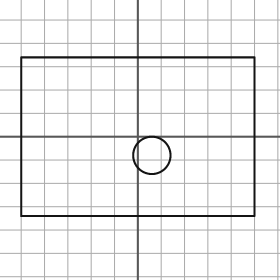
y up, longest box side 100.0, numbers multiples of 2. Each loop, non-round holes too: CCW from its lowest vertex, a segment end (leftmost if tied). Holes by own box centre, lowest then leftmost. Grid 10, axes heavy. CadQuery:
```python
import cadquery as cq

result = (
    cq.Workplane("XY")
    .moveTo(-50.0, -34.0)
    .lineTo(50.0, -34.0)
    .lineTo(50.0, 34.0)
    .lineTo(-50.0, 34.0)
    .close()
    .moveTo(6.0, -8.0)
    .circle(8.0)
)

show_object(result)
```